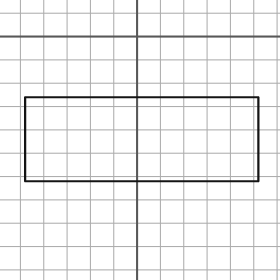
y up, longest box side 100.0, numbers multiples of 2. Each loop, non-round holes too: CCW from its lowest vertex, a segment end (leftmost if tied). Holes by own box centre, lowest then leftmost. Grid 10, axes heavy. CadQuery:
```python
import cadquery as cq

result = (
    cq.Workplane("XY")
    .moveTo(-48.0, -62.0)
    .lineTo(52.0, -62.0)
    .lineTo(52.0, -26.0)
    .lineTo(-48.0, -26.0)
    .close()
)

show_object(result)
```